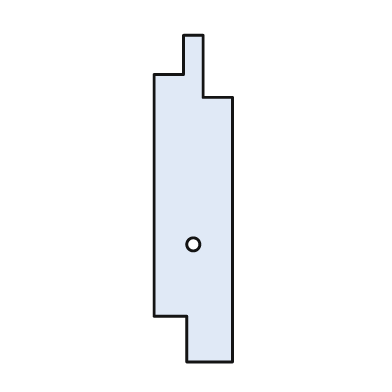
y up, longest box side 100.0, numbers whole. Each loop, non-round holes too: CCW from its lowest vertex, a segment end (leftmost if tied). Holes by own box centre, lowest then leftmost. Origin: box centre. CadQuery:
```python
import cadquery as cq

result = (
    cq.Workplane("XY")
    .moveTo(-2.0, -50.0)
    .lineTo(12.0, -50.0)
    .lineTo(12.0, 31.0)
    .lineTo(3.0, 31.0)
    .lineTo(3.0, 50.0)
    .lineTo(-3.0, 50.0)
    .lineTo(-3.0, 38.0)
    .lineTo(-12.0, 38.0)
    .lineTo(-12.0, -36.0)
    .lineTo(-2.0, -36.0)
    .close()
    .moveTo(0.0, -14.0)
    .circle(2.0)
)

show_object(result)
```